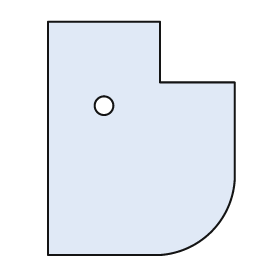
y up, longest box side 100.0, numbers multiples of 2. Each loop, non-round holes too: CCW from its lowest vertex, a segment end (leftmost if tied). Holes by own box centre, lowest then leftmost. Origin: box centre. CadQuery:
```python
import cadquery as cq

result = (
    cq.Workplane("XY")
    .moveTo(-40.0, -50.0)
    .lineTo(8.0, -50.0)
    .threePointArc((30.0, -40.0), (40.0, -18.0))
    .lineTo(40.0, 24.0)
    .lineTo(8.0, 24.0)
    .lineTo(8.0, 50.0)
    .lineTo(-40.0, 50.0)
    .close()
    .moveTo(-16.0, 14.0)
    .circle(4.0)
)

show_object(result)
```